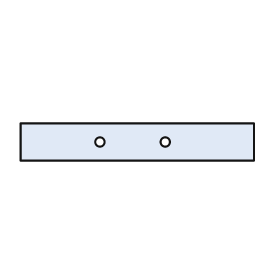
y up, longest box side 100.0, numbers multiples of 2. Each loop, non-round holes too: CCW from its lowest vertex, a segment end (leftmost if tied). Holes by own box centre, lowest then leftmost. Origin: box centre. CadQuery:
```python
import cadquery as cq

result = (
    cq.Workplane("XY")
    .moveTo(-50.0, -8.0)
    .lineTo(50.0, -8.0)
    .lineTo(50.0, 8.0)
    .lineTo(-50.0, 8.0)
    .close()
    .moveTo(-16.0, 0.0)
    .circle(2.0)
    .moveTo(12.0, 0.0)
    .circle(2.0)
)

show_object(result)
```